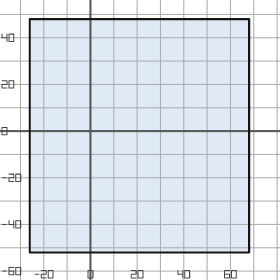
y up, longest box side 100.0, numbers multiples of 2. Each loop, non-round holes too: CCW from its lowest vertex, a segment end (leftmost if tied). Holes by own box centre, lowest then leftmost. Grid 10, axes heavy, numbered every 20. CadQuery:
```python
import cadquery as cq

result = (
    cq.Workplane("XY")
    .moveTo(-26.0, -52.0)
    .lineTo(68.0, -52.0)
    .lineTo(68.0, 48.0)
    .lineTo(-26.0, 48.0)
    .close()
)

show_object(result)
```